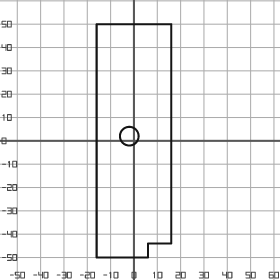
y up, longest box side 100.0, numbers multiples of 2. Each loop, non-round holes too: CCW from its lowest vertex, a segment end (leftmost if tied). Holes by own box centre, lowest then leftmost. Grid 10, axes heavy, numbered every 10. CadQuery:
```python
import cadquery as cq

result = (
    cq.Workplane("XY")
    .moveTo(-16.0, -50.0)
    .lineTo(6.0, -50.0)
    .lineTo(6.0, -44.0)
    .lineTo(16.0, -44.0)
    .lineTo(16.0, 50.0)
    .lineTo(-16.0, 50.0)
    .close()
    .moveTo(-2.0, 2.0)
    .circle(4.0)
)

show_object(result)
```